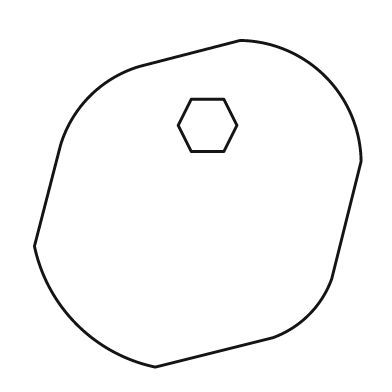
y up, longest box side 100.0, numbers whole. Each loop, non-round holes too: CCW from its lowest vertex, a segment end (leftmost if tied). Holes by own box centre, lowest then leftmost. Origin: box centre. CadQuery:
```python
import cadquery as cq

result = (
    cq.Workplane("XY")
    .moveTo(-13.0, -50.0)
    .lineTo(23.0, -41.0)
    .threePointArc((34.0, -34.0), (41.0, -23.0))
    .lineTo(50.0, 13.0)
    .threePointArc((39.0, 39.0), (13.0, 50.0))
    .lineTo(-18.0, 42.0)
    .threePointArc((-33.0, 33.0), (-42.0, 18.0))
    .lineTo(-50.0, -13.0)
    .threePointArc((-37.0, -37.0), (-13.0, -50.0))
    .close()
    .moveTo(-2.0, 16.0)
    .lineTo(8.0, 16.0)
    .lineTo(12.0, 24.0)
    .lineTo(8.0, 32.0)
    .lineTo(-2.0, 32.0)
    .lineTo(-6.0, 24.0)
    .close()
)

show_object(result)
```